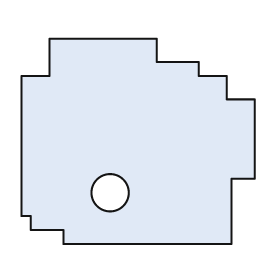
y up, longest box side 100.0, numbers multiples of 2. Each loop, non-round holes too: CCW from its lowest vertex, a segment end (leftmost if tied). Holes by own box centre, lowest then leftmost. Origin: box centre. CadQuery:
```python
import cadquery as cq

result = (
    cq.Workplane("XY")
    .moveTo(-32.0, -44.0)
    .lineTo(40.0, -44.0)
    .lineTo(40.0, -16.0)
    .lineTo(50.0, -16.0)
    .lineTo(50.0, 18.0)
    .lineTo(38.0, 18.0)
    .lineTo(38.0, 28.0)
    .lineTo(26.0, 28.0)
    .lineTo(26.0, 34.0)
    .lineTo(8.0, 34.0)
    .lineTo(8.0, 44.0)
    .lineTo(-38.0, 44.0)
    .lineTo(-38.0, 28.0)
    .lineTo(-50.0, 28.0)
    .lineTo(-50.0, -32.0)
    .lineTo(-46.0, -32.0)
    .lineTo(-46.0, -38.0)
    .lineTo(-32.0, -38.0)
    .close()
    .moveTo(-12.0, -22.0)
    .circle(8.0)
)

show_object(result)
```